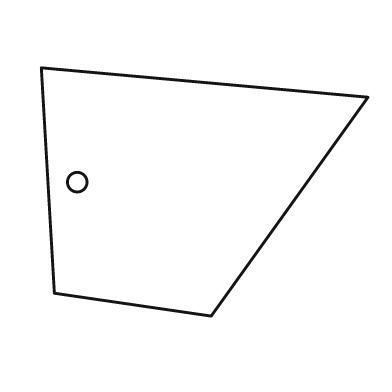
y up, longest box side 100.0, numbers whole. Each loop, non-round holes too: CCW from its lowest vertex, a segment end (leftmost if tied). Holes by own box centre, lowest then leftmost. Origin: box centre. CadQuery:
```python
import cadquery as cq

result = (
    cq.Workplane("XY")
    .moveTo(2.0, -38.0)
    .lineTo(50.0, 29.0)
    .lineTo(-50.0, 38.0)
    .lineTo(-46.0, -31.0)
    .close()
    .moveTo(-39.0, 3.0)
    .circle(3.0)
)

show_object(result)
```